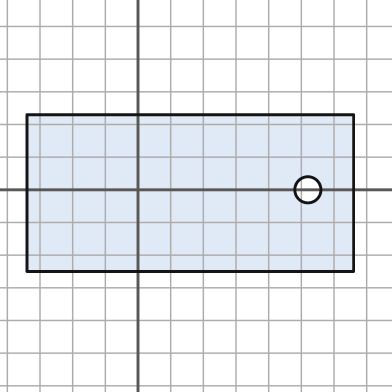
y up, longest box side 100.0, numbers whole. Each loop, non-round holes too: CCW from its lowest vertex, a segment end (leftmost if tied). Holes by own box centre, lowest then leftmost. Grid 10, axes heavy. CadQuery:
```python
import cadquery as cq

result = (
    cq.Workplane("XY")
    .moveTo(-34.0, -25.0)
    .lineTo(66.0, -25.0)
    .lineTo(66.0, 23.0)
    .lineTo(-34.0, 23.0)
    .close()
    .moveTo(52.0, 0.0)
    .circle(4.0)
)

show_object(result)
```